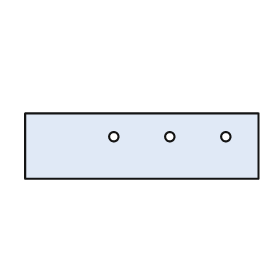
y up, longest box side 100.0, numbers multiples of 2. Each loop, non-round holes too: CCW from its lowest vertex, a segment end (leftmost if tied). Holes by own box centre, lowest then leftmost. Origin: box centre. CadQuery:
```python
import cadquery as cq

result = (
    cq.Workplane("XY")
    .moveTo(-50.0, -14.0)
    .lineTo(50.0, -14.0)
    .lineTo(50.0, 14.0)
    .lineTo(-50.0, 14.0)
    .close()
    .moveTo(-12.0, 4.0)
    .circle(2.0)
    .moveTo(12.0, 4.0)
    .circle(2.0)
    .moveTo(36.0, 4.0)
    .circle(2.0)
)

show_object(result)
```